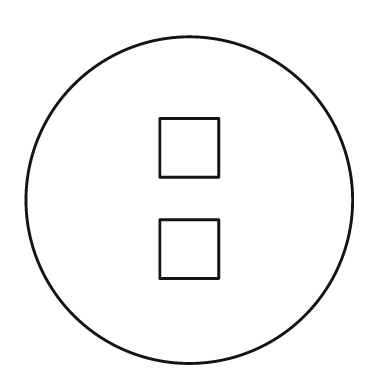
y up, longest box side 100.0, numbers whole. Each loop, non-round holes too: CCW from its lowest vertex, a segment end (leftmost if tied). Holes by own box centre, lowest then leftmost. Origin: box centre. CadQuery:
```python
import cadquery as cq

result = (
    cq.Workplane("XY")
    .moveTo(0.0, 0.0)
    .circle(50.0)
    .moveTo(-9.0, -24.0)
    .lineTo(9.0, -24.0)
    .lineTo(9.0, -6.0)
    .lineTo(-9.0, -6.0)
    .close()
    .moveTo(-9.0, 7.0)
    .lineTo(9.0, 7.0)
    .lineTo(9.0, 25.0)
    .lineTo(-9.0, 25.0)
    .close()
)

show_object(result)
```